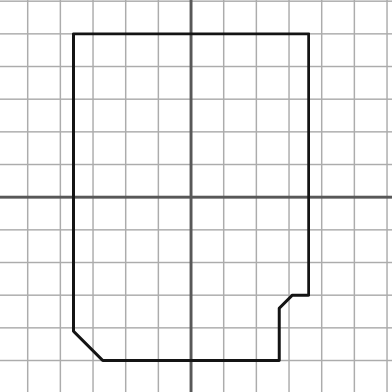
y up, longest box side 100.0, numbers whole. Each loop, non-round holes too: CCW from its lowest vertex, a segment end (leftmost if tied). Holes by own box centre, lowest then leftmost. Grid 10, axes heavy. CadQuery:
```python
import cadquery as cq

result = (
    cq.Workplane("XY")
    .moveTo(-27.0, -50.0)
    .lineTo(27.0, -50.0)
    .lineTo(27.0, -34.0)
    .lineTo(31.0, -30.0)
    .lineTo(36.0, -30.0)
    .lineTo(36.0, 50.0)
    .lineTo(-36.0, 50.0)
    .lineTo(-36.0, -41.0)
    .close()
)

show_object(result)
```